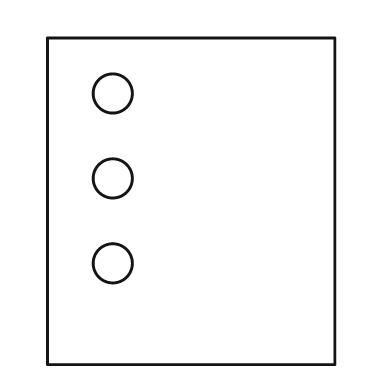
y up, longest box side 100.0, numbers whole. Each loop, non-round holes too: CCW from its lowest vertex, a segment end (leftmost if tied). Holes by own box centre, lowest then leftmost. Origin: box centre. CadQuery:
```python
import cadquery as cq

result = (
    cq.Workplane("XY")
    .moveTo(-44.0, -50.0)
    .lineTo(44.0, -50.0)
    .lineTo(44.0, 50.0)
    .lineTo(-44.0, 50.0)
    .close()
    .moveTo(-24.0, -19.0)
    .circle(6.0)
    .moveTo(-24.0, 7.0)
    .circle(6.0)
    .moveTo(-24.0, 33.0)
    .circle(6.0)
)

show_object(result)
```